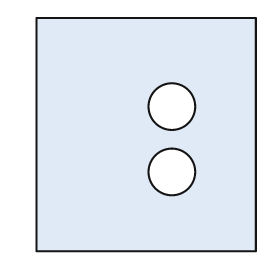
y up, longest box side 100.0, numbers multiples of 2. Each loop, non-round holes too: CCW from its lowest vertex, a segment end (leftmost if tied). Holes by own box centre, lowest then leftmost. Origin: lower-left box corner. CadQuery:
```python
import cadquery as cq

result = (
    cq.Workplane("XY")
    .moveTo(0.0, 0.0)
    .lineTo(94.0, 0.0)
    .lineTo(94.0, 100.0)
    .lineTo(0.0, 100.0)
    .close()
    .moveTo(58.0, 34.0)
    .circle(10.0)
    .moveTo(58.0, 62.0)
    .circle(10.0)
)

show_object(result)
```